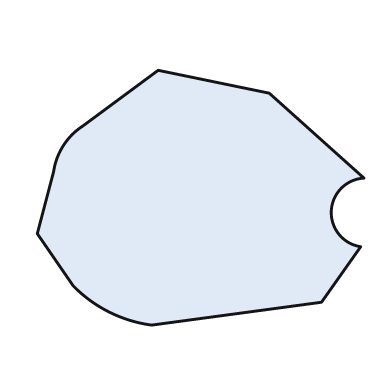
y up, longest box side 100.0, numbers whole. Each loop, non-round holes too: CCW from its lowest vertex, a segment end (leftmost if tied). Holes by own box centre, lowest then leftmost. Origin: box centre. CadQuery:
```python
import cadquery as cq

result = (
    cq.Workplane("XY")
    .moveTo(-15.0, -39.0)
    .lineTo(37.0, -32.0)
    .lineTo(49.0, -15.0)
    .threePointArc((40.0, -4.0), (50.0, 6.0))
    .lineTo(21.0, 32.0)
    .lineTo(-13.0, 39.0)
    .lineTo(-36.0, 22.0)
    .threePointArc((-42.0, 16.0), (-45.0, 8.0))
    .lineTo(-50.0, -11.0)
    .lineTo(-39.0, -27.0)
    .threePointArc((-28.0, -35.0), (-15.0, -39.0))
    .close()
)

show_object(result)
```